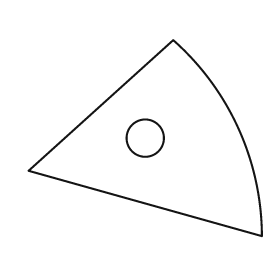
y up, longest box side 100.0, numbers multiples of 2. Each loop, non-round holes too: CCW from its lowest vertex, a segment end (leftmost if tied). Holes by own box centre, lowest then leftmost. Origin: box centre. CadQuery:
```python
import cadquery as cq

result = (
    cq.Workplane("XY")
    .moveTo(50.0, -42.0)
    .threePointArc((40.0, 4.0), (12.0, 42.0))
    .lineTo(-50.0, -14.0)
    .close()
    .moveTo(0.0, 0.0)
    .circle(8.0)
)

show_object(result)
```